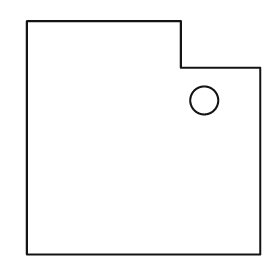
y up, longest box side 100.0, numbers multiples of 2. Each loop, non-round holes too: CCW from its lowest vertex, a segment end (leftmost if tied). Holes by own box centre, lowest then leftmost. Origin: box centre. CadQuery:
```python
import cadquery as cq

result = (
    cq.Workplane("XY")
    .moveTo(-50.0, -50.0)
    .lineTo(50.0, -50.0)
    .lineTo(50.0, 30.0)
    .lineTo(16.0, 30.0)
    .lineTo(16.0, 50.0)
    .lineTo(-50.0, 50.0)
    .close()
    .moveTo(26.0, 16.0)
    .circle(6.0)
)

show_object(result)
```